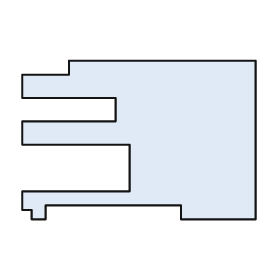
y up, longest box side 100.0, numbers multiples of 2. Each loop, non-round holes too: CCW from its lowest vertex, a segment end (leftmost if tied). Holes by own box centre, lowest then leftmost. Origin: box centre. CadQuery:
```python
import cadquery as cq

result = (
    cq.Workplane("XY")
    .moveTo(-46.0, -34.0)
    .lineTo(-40.0, -34.0)
    .lineTo(-40.0, -28.0)
    .lineTo(18.0, -28.0)
    .lineTo(18.0, -34.0)
    .lineTo(50.0, -34.0)
    .lineTo(50.0, 34.0)
    .lineTo(-30.0, 34.0)
    .lineTo(-30.0, 28.0)
    .lineTo(-50.0, 28.0)
    .lineTo(-50.0, 18.0)
    .lineTo(-10.0, 18.0)
    .lineTo(-10.0, 8.0)
    .lineTo(-50.0, 8.0)
    .lineTo(-50.0, -2.0)
    .lineTo(-4.0, -2.0)
    .lineTo(-4.0, -22.0)
    .lineTo(-50.0, -22.0)
    .lineTo(-50.0, -30.0)
    .lineTo(-46.0, -30.0)
    .close()
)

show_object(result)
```